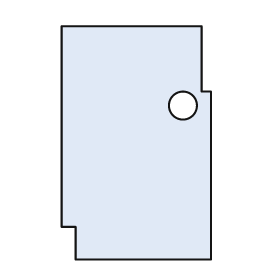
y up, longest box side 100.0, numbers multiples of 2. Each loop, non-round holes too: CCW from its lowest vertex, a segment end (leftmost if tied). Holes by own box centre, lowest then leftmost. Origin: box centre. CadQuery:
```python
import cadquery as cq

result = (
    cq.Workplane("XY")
    .moveTo(-26.0, -50.0)
    .lineTo(32.0, -50.0)
    .lineTo(32.0, 22.0)
    .lineTo(28.0, 22.0)
    .lineTo(28.0, 50.0)
    .lineTo(-32.0, 50.0)
    .lineTo(-32.0, -36.0)
    .lineTo(-26.0, -36.0)
    .close()
    .moveTo(20.0, 16.0)
    .circle(6.0)
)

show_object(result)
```